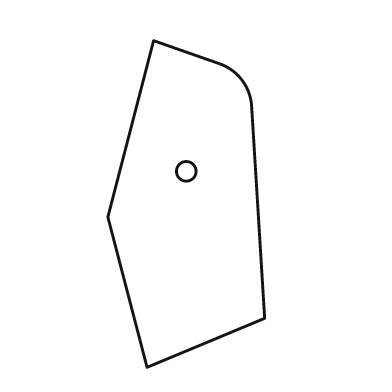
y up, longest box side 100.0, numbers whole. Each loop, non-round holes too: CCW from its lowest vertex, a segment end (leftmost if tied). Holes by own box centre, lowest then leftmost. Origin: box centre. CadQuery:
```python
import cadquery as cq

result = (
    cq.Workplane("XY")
    .moveTo(-12.0, -50.0)
    .lineTo(24.0, -35.0)
    .lineTo(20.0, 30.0)
    .threePointArc((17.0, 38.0), (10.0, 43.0))
    .lineTo(-10.0, 50.0)
    .lineTo(-24.0, -4.0)
    .close()
    .moveTo(0.0, 10.0)
    .circle(3.0)
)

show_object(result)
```